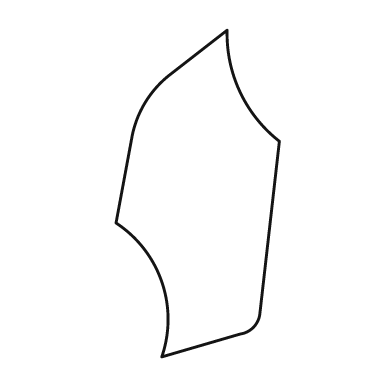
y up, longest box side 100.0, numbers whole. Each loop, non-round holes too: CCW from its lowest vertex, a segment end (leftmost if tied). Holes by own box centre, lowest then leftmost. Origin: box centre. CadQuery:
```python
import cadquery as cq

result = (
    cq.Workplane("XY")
    .moveTo(-11.0, -50.0)
    .lineTo(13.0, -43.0)
    .threePointArc((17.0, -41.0), (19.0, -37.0))
    .lineTo(25.0, 16.0)
    .threePointArc((13.0, 31.0), (9.0, 50.0))
    .lineTo(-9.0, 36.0)
    .threePointArc((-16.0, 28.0), (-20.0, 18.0))
    .lineTo(-25.0, -9.0)
    .threePointArc((-11.0, -27.0), (-11.0, -50.0))
    .close()
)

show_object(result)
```